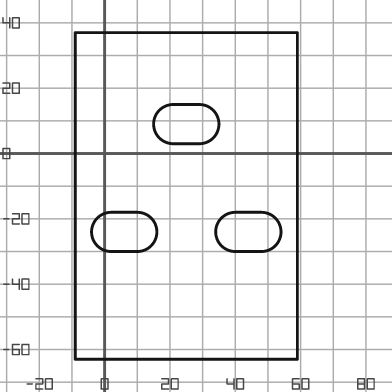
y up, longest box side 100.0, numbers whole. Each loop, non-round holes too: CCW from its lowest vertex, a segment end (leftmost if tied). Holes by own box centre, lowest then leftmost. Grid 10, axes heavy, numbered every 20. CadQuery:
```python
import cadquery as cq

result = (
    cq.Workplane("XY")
    .moveTo(-9.0, -63.0)
    .lineTo(59.0, -63.0)
    .lineTo(59.0, 37.0)
    .lineTo(-9.0, 37.0)
    .close()
    .moveTo(2.0, -30.0)
    .lineTo(10.0, -30.0)
    .threePointArc((16.0, -24.0), (10.0, -18.0))
    .lineTo(2.0, -18.0)
    .threePointArc((-4.0, -24.0), (2.0, -30.0))
    .close()
    .moveTo(40.0, -30.0)
    .lineTo(48.0, -30.0)
    .threePointArc((54.0, -24.0), (48.0, -18.0))
    .lineTo(40.0, -18.0)
    .threePointArc((34.0, -24.0), (40.0, -30.0))
    .close()
    .moveTo(21.0, 3.0)
    .lineTo(29.0, 3.0)
    .threePointArc((35.0, 9.0), (29.0, 15.0))
    .lineTo(21.0, 15.0)
    .threePointArc((15.0, 9.0), (21.0, 3.0))
    .close()
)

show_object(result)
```